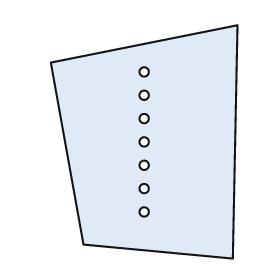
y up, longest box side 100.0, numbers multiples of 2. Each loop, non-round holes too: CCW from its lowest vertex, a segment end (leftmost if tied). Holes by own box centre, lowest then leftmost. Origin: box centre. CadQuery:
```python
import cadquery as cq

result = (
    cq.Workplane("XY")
    .moveTo(38.0, -50.0)
    .lineTo(40.0, 50.0)
    .lineTo(-40.0, 34.0)
    .lineTo(-26.0, -44.0)
    .close()
    .moveTo(0.0, -30.0)
    .circle(2.0)
    .moveTo(0.0, -20.0)
    .circle(2.0)
    .moveTo(0.0, -10.0)
    .circle(2.0)
    .moveTo(0.0, 0.0)
    .circle(2.0)
    .moveTo(0.0, 10.0)
    .circle(2.0)
    .moveTo(0.0, 20.0)
    .circle(2.0)
    .moveTo(0.0, 30.0)
    .circle(2.0)
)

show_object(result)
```